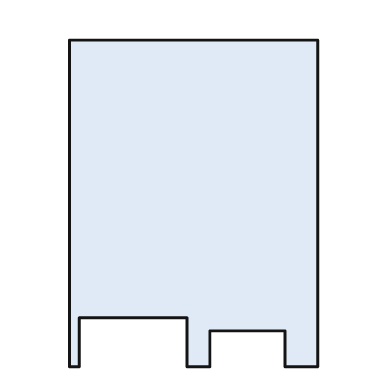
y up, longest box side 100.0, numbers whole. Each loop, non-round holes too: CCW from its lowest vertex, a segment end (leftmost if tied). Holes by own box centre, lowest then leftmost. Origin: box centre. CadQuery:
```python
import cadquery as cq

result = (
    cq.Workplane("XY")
    .moveTo(-38.0, -50.0)
    .lineTo(-35.0, -50.0)
    .lineTo(-35.0, -35.0)
    .lineTo(-2.0, -35.0)
    .lineTo(-2.0, -50.0)
    .lineTo(5.0, -50.0)
    .lineTo(5.0, -39.0)
    .lineTo(28.0, -39.0)
    .lineTo(28.0, -50.0)
    .lineTo(38.0, -50.0)
    .lineTo(38.0, 50.0)
    .lineTo(-38.0, 50.0)
    .close()
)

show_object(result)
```